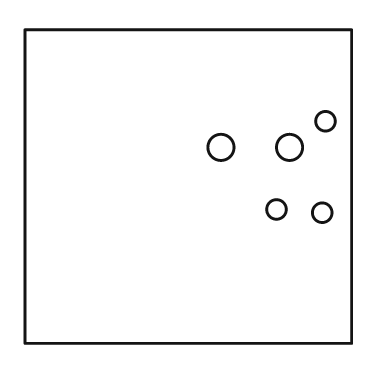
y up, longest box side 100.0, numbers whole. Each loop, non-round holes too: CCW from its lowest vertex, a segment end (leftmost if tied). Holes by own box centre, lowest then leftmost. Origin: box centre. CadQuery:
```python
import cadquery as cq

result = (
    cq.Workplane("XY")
    .moveTo(-50.0, -48.0)
    .lineTo(50.0, -48.0)
    .lineTo(50.0, 48.0)
    .lineTo(-50.0, 48.0)
    .close()
    .moveTo(41.0, -8.0)
    .circle(3.0)
    .moveTo(27.0, -7.0)
    .circle(3.0)
    .moveTo(10.0, 12.0)
    .circle(4.0)
    .moveTo(31.0, 12.0)
    .circle(4.0)
    .moveTo(42.0, 20.0)
    .circle(3.0)
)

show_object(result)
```